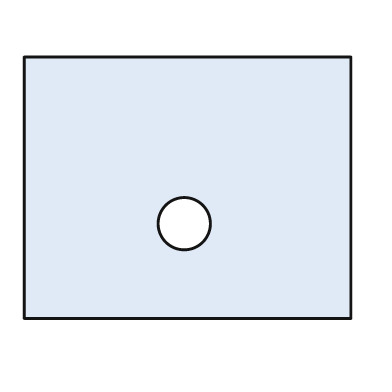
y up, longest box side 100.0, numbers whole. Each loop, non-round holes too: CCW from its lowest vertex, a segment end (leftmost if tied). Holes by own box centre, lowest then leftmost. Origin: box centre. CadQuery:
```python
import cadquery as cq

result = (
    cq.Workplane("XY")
    .moveTo(-50.0, -40.0)
    .lineTo(50.0, -40.0)
    .lineTo(50.0, 40.0)
    .lineTo(-50.0, 40.0)
    .close()
    .moveTo(-1.0, -11.0)
    .circle(8.0)
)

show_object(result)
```